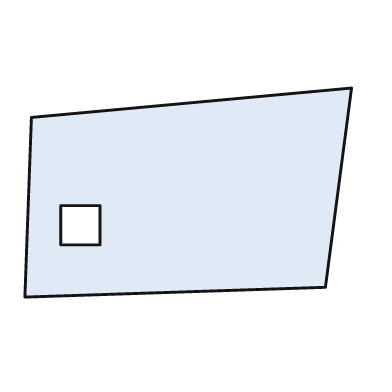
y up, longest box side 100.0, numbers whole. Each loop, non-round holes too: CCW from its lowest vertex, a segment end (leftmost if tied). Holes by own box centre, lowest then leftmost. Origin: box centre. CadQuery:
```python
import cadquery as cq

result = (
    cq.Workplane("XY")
    .moveTo(-50.0, -32.0)
    .lineTo(42.0, -29.0)
    .lineTo(50.0, 32.0)
    .lineTo(-48.0, 23.0)
    .close()
    .moveTo(-39.0, -16.0)
    .lineTo(-27.0, -16.0)
    .lineTo(-27.0, -4.0)
    .lineTo(-39.0, -4.0)
    .close()
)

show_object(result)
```